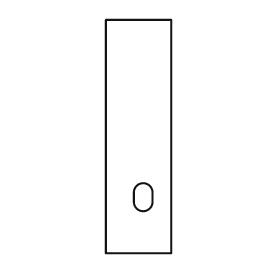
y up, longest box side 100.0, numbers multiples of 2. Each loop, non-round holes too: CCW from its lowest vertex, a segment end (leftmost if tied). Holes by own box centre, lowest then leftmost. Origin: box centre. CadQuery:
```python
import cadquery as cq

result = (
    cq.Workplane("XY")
    .moveTo(-14.0, -50.0)
    .lineTo(14.0, -50.0)
    .lineTo(14.0, 50.0)
    .lineTo(-14.0, 50.0)
    .close()
    .moveTo(-2.0, -28.0)
    .threePointArc((2.0, -32.0), (6.0, -28.0))
    .lineTo(6.0, -24.0)
    .threePointArc((2.0, -20.0), (-2.0, -24.0))
    .close()
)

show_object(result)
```